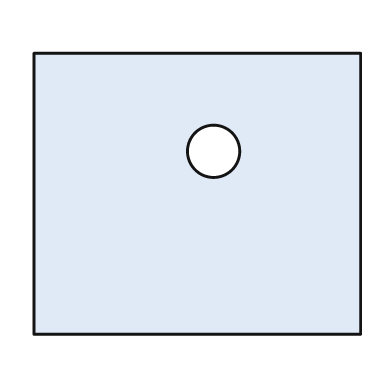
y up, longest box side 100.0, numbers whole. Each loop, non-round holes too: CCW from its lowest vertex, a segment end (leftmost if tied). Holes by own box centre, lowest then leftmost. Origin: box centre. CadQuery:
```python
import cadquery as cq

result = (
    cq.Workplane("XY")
    .moveTo(-50.0, -43.0)
    .lineTo(50.0, -43.0)
    .lineTo(50.0, 43.0)
    .lineTo(-50.0, 43.0)
    .close()
    .moveTo(5.0, 13.0)
    .circle(8.0)
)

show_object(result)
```